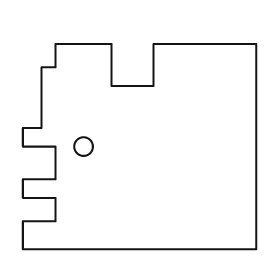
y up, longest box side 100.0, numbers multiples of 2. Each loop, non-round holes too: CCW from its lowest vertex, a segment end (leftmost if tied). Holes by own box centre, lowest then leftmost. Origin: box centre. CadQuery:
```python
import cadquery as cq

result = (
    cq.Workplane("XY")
    .moveTo(-50.0, -44.0)
    .lineTo(50.0, -44.0)
    .lineTo(50.0, 44.0)
    .lineTo(6.0, 44.0)
    .lineTo(6.0, 26.0)
    .lineTo(-12.0, 26.0)
    .lineTo(-12.0, 44.0)
    .lineTo(-36.0, 44.0)
    .lineTo(-36.0, 34.0)
    .lineTo(-42.0, 34.0)
    .lineTo(-42.0, 8.0)
    .lineTo(-50.0, 8.0)
    .lineTo(-50.0, 0.0)
    .lineTo(-36.0, 0.0)
    .lineTo(-36.0, -14.0)
    .lineTo(-50.0, -14.0)
    .lineTo(-50.0, -22.0)
    .lineTo(-36.0, -22.0)
    .lineTo(-36.0, -32.0)
    .lineTo(-50.0, -32.0)
    .close()
    .moveTo(-24.0, 0.0)
    .circle(4.0)
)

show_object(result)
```